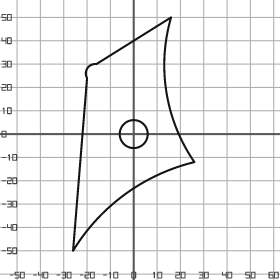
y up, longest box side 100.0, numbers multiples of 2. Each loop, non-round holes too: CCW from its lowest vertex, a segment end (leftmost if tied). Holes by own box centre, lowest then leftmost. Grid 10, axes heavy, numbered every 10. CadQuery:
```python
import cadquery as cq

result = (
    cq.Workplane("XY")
    .moveTo(-26.0, -50.0)
    .threePointArc((-4.0, -26.0), (26.0, -12.0))
    .threePointArc((14.0, 18.0), (16.0, 50.0))
    .lineTo(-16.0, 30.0)
    .threePointArc((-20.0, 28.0), (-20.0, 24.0))
    .close()
    .moveTo(0.0, 0.0)
    .circle(6.0)
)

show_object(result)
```